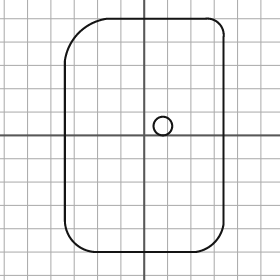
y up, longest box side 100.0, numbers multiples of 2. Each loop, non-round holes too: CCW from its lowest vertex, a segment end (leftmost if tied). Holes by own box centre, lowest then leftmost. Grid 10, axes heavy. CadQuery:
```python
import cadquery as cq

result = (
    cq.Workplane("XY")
    .moveTo(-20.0, -50.0)
    .lineTo(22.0, -50.0)
    .threePointArc((30.0, -46.0), (34.0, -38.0))
    .lineTo(34.0, 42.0)
    .threePointArc((32.0, 48.0), (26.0, 50.0))
    .lineTo(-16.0, 50.0)
    .threePointArc((-28.0, 44.0), (-34.0, 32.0))
    .lineTo(-34.0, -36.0)
    .threePointArc((-30.0, -46.0), (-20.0, -50.0))
    .close()
    .moveTo(8.0, 4.0)
    .circle(4.0)
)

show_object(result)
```